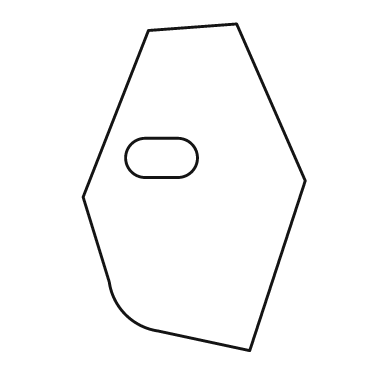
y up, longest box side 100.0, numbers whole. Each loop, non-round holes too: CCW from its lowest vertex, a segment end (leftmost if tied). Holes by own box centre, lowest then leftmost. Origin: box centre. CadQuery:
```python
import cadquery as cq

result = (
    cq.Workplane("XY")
    .moveTo(17.0, -50.0)
    .lineTo(34.0, 2.0)
    .lineTo(13.0, 50.0)
    .lineTo(-14.0, 48.0)
    .lineTo(-34.0, -3.0)
    .lineTo(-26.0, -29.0)
    .threePointArc((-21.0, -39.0), (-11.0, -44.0))
    .close()
    .moveTo(-15.0, 3.0)
    .lineTo(-5.0, 3.0)
    .threePointArc((1.0, 9.0), (-5.0, 15.0))
    .lineTo(-15.0, 15.0)
    .threePointArc((-21.0, 9.0), (-15.0, 3.0))
    .close()
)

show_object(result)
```